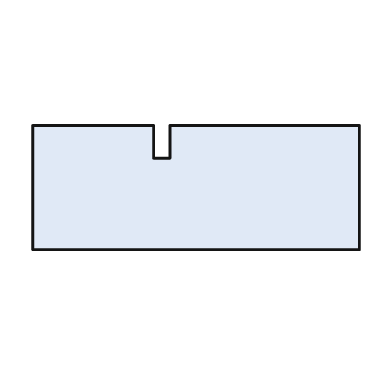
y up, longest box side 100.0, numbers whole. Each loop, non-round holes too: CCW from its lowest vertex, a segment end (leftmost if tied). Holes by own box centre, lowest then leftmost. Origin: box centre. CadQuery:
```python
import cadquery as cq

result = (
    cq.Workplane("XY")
    .moveTo(-50.0, -19.0)
    .lineTo(50.0, -19.0)
    .lineTo(50.0, 19.0)
    .lineTo(-8.0, 19.0)
    .lineTo(-8.0, 9.0)
    .lineTo(-13.0, 9.0)
    .lineTo(-13.0, 19.0)
    .lineTo(-50.0, 19.0)
    .close()
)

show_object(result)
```